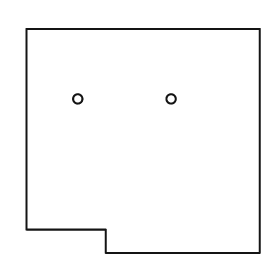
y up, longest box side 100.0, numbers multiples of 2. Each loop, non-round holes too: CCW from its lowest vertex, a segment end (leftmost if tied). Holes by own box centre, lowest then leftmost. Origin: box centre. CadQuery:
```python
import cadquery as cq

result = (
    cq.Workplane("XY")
    .moveTo(-16.0, -48.0)
    .lineTo(50.0, -48.0)
    .lineTo(50.0, 48.0)
    .lineTo(-50.0, 48.0)
    .lineTo(-50.0, -38.0)
    .lineTo(-16.0, -38.0)
    .close()
    .moveTo(-28.0, 18.0)
    .circle(2.0)
    .moveTo(12.0, 18.0)
    .circle(2.0)
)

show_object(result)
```